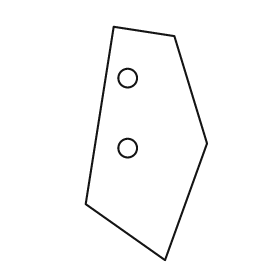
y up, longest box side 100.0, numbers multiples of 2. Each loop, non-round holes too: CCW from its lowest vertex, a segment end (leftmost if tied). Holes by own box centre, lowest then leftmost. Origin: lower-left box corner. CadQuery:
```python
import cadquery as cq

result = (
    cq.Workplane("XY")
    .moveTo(34.0, 0.0)
    .lineTo(52.0, 50.0)
    .lineTo(38.0, 96.0)
    .lineTo(12.0, 100.0)
    .lineTo(0.0, 24.0)
    .close()
    .moveTo(18.0, 48.0)
    .circle(4.0)
    .moveTo(18.0, 78.0)
    .circle(4.0)
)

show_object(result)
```